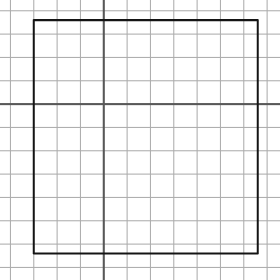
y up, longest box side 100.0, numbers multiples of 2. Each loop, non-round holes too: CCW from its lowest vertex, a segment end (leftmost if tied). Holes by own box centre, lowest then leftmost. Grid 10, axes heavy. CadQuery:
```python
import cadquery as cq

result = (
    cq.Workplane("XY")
    .moveTo(-30.0, -64.0)
    .lineTo(66.0, -64.0)
    .lineTo(66.0, 36.0)
    .lineTo(-30.0, 36.0)
    .close()
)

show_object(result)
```